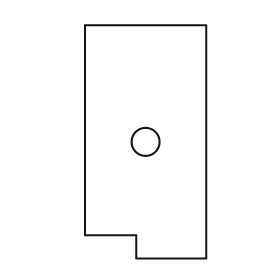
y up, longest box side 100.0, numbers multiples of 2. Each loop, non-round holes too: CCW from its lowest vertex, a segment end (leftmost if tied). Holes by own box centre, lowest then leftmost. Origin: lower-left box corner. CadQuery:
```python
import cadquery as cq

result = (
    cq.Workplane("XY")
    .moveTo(22.0, 0.0)
    .lineTo(52.0, 0.0)
    .lineTo(52.0, 100.0)
    .lineTo(0.0, 100.0)
    .lineTo(0.0, 10.0)
    .lineTo(22.0, 10.0)
    .close()
    .moveTo(26.0, 50.0)
    .circle(6.0)
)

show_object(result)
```